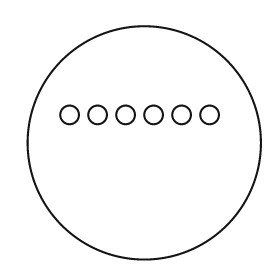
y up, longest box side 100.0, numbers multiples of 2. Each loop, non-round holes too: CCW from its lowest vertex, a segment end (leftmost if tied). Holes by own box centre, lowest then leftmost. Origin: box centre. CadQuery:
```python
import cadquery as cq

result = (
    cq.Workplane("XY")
    .moveTo(0.0, 0.0)
    .circle(50.0)
    .moveTo(-32.0, 12.0)
    .circle(4.0)
    .moveTo(-20.0, 12.0)
    .circle(4.0)
    .moveTo(-8.0, 12.0)
    .circle(4.0)
    .moveTo(4.0, 12.0)
    .circle(4.0)
    .moveTo(16.0, 12.0)
    .circle(4.0)
    .moveTo(28.0, 12.0)
    .circle(4.0)
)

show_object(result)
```